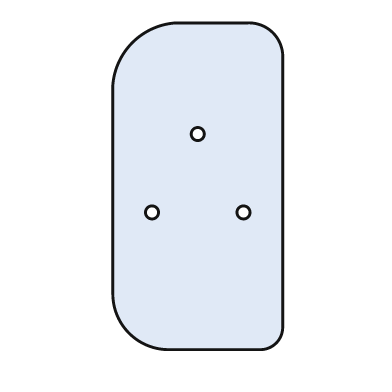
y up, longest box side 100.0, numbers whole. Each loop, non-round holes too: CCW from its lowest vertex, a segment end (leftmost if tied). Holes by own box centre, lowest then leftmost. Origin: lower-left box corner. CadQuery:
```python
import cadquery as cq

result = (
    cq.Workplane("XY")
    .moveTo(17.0, 0.0)
    .lineTo(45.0, 0.0)
    .threePointArc((50.0, 2.0), (52.0, 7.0))
    .lineTo(52.0, 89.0)
    .threePointArc((49.0, 97.0), (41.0, 100.0))
    .lineTo(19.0, 100.0)
    .threePointArc((6.0, 94.0), (0.0, 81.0))
    .lineTo(0.0, 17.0)
    .threePointArc((5.0, 5.0), (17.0, 0.0))
    .close()
    .moveTo(12.0, 42.0)
    .circle(2.0)
    .moveTo(40.0, 42.0)
    .circle(2.0)
    .moveTo(26.0, 66.0)
    .circle(2.0)
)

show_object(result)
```